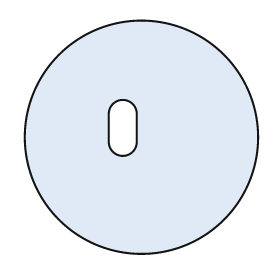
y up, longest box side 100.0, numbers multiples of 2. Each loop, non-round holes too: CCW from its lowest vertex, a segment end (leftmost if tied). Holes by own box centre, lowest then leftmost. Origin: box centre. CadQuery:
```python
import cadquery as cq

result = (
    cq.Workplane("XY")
    .moveTo(0.0, 0.0)
    .circle(50.0)
    .moveTo(-14.0, -2.0)
    .threePointArc((-8.0, -8.0), (-2.0, -2.0))
    .lineTo(-2.0, 10.0)
    .threePointArc((-8.0, 16.0), (-14.0, 10.0))
    .close()
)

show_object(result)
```